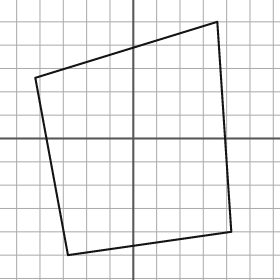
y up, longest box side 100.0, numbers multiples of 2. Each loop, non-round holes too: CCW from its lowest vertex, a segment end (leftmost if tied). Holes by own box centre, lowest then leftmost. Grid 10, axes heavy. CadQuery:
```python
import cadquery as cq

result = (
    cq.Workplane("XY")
    .moveTo(-28.0, -50.0)
    .lineTo(42.0, -40.0)
    .lineTo(36.0, 50.0)
    .lineTo(-42.0, 26.0)
    .close()
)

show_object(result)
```